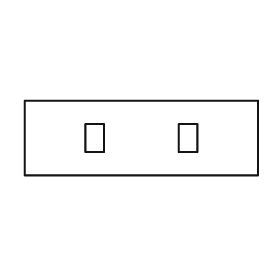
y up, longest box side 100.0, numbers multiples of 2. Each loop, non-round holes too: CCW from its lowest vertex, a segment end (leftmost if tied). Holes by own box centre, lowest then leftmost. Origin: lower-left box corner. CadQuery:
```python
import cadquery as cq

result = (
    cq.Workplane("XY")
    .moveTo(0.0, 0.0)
    .lineTo(100.0, 0.0)
    .lineTo(100.0, 32.0)
    .lineTo(0.0, 32.0)
    .close()
    .moveTo(26.0, 10.0)
    .lineTo(34.0, 10.0)
    .lineTo(34.0, 22.0)
    .lineTo(26.0, 22.0)
    .close()
    .moveTo(66.0, 10.0)
    .lineTo(74.0, 10.0)
    .lineTo(74.0, 22.0)
    .lineTo(66.0, 22.0)
    .close()
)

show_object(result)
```